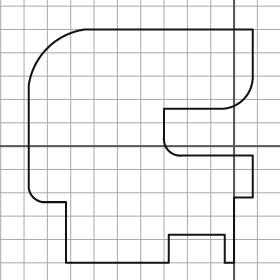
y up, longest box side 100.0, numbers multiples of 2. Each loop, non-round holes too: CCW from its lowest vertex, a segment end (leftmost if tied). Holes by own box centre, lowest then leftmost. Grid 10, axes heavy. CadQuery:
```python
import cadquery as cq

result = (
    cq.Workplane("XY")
    .moveTo(-72.0, -50.0)
    .lineTo(-28.0, -50.0)
    .lineTo(-28.0, -38.0)
    .lineTo(-4.0, -38.0)
    .lineTo(-4.0, -50.0)
    .lineTo(0.0, -50.0)
    .lineTo(0.0, -22.0)
    .lineTo(8.0, -22.0)
    .lineTo(8.0, -4.0)
    .lineTo(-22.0, -4.0)
    .threePointArc((-28.0, -2.0), (-30.0, 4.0))
    .lineTo(-30.0, 16.0)
    .lineTo(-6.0, 16.0)
    .threePointArc((4.0, 20.0), (8.0, 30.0))
    .lineTo(8.0, 50.0)
    .lineTo(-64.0, 50.0)
    .threePointArc((-80.0, 42.0), (-88.0, 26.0))
    .lineTo(-88.0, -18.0)
    .threePointArc((-86.0, -22.0), (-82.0, -24.0))
    .lineTo(-72.0, -24.0)
    .close()
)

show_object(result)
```